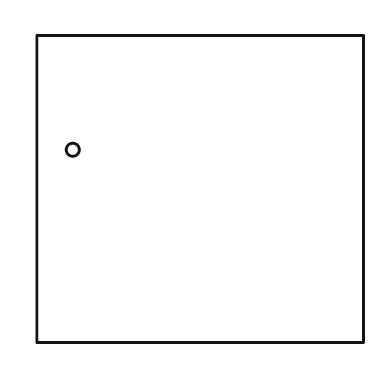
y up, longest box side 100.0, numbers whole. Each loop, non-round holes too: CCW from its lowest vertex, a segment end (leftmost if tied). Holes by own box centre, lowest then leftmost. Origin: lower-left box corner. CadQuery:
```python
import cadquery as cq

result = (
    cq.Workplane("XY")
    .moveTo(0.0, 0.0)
    .lineTo(100.0, 0.0)
    .lineTo(100.0, 94.0)
    .lineTo(0.0, 94.0)
    .close()
    .moveTo(11.0, 59.0)
    .circle(2.0)
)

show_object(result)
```